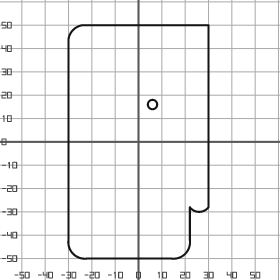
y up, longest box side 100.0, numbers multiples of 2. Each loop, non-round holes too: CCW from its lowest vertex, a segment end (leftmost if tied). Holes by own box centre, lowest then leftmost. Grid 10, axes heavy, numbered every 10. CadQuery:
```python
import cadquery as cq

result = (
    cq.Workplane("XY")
    .moveTo(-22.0, -50.0)
    .lineTo(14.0, -50.0)
    .threePointArc((20.0, -48.0), (22.0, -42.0))
    .lineTo(22.0, -28.0)
    .threePointArc((26.0, -30.0), (30.0, -28.0))
    .lineTo(30.0, 50.0)
    .lineTo(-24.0, 50.0)
    .threePointArc((-28.0, 48.0), (-30.0, 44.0))
    .lineTo(-30.0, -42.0)
    .threePointArc((-28.0, -48.0), (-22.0, -50.0))
    .close()
    .moveTo(6.0, 16.0)
    .circle(2.0)
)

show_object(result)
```